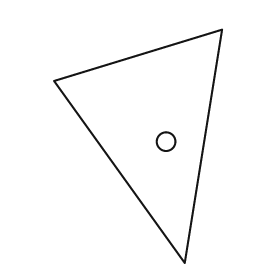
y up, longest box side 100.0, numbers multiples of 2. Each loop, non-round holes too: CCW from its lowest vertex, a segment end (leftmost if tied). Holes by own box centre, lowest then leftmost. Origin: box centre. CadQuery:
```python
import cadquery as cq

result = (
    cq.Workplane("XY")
    .moveTo(20.0, -50.0)
    .lineTo(36.0, 50.0)
    .lineTo(-36.0, 28.0)
    .close()
    .moveTo(12.0, 2.0)
    .circle(4.0)
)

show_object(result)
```